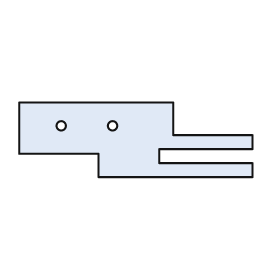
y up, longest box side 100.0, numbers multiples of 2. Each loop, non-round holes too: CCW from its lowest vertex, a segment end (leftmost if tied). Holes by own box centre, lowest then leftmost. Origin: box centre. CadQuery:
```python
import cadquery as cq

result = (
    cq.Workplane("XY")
    .moveTo(-16.0, -16.0)
    .lineTo(50.0, -16.0)
    .lineTo(50.0, -10.0)
    .lineTo(10.0, -10.0)
    .lineTo(10.0, -4.0)
    .lineTo(50.0, -4.0)
    .lineTo(50.0, 2.0)
    .lineTo(16.0, 2.0)
    .lineTo(16.0, 16.0)
    .lineTo(-50.0, 16.0)
    .lineTo(-50.0, -6.0)
    .lineTo(-16.0, -6.0)
    .close()
    .moveTo(-32.0, 6.0)
    .circle(2.0)
    .moveTo(-10.0, 6.0)
    .circle(2.0)
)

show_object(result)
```